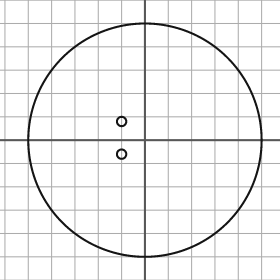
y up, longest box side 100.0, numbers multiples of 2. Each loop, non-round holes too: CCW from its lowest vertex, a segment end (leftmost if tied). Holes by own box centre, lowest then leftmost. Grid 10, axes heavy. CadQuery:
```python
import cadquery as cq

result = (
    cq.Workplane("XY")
    .moveTo(0.0, 0.0)
    .circle(50.0)
    .moveTo(-10.0, -6.0)
    .circle(2.0)
    .moveTo(-10.0, 8.0)
    .circle(2.0)
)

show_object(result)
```